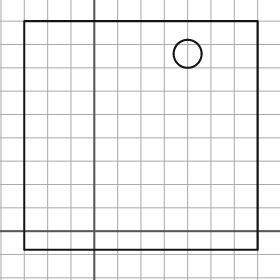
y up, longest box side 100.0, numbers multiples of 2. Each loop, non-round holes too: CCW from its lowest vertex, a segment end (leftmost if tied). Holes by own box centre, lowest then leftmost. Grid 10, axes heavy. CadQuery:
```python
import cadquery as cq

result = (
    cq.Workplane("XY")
    .moveTo(-30.0, -8.0)
    .lineTo(70.0, -8.0)
    .lineTo(70.0, 90.0)
    .lineTo(-30.0, 90.0)
    .close()
    .moveTo(40.0, 76.0)
    .circle(6.0)
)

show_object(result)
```